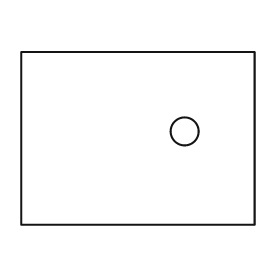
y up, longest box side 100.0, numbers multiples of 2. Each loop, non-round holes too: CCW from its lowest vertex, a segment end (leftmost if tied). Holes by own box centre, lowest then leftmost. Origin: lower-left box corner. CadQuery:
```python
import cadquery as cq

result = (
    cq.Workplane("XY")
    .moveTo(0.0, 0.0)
    .lineTo(100.0, 0.0)
    .lineTo(100.0, 74.0)
    .lineTo(0.0, 74.0)
    .close()
    .moveTo(70.0, 40.0)
    .circle(6.0)
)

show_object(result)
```